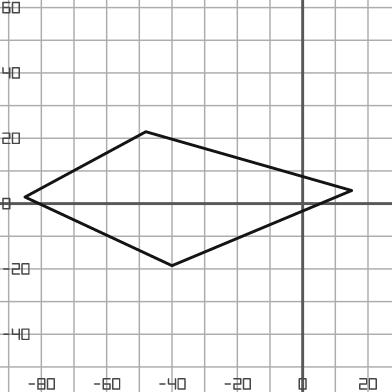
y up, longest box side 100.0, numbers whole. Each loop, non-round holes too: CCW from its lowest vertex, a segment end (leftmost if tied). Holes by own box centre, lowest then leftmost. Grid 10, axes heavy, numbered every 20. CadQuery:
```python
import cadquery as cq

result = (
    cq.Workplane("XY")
    .moveTo(-40.0, -19.0)
    .lineTo(15.0, 4.0)
    .lineTo(-48.0, 22.0)
    .lineTo(-85.0, 2.0)
    .close()
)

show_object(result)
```